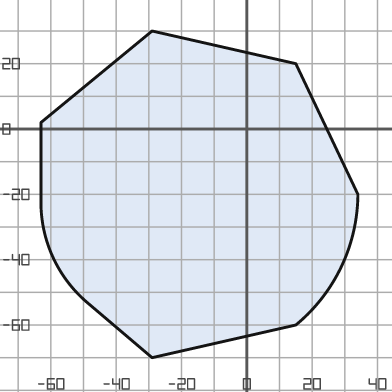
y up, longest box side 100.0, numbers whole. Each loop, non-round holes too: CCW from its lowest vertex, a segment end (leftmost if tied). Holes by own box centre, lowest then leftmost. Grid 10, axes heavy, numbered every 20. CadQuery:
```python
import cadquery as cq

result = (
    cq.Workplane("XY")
    .moveTo(-29.0, -70.0)
    .lineTo(15.0, -60.0)
    .threePointArc((29.0, -42.0), (34.0, -20.0))
    .lineTo(15.0, 20.0)
    .lineTo(-29.0, 30.0)
    .lineTo(-63.0, 2.0)
    .lineTo(-63.0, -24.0)
    .threePointArc((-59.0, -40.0), (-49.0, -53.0))
    .close()
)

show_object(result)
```